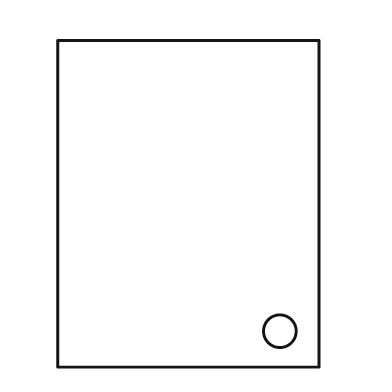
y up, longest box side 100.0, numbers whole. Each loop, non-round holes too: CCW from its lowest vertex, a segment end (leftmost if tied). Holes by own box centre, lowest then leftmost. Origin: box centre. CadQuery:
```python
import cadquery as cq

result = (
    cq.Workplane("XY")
    .moveTo(-40.0, -50.0)
    .lineTo(40.0, -50.0)
    .lineTo(40.0, 50.0)
    .lineTo(-40.0, 50.0)
    .close()
    .moveTo(28.0, -39.0)
    .circle(5.0)
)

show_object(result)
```